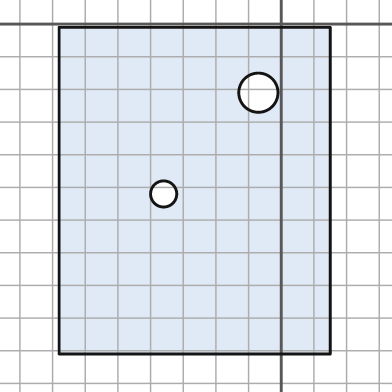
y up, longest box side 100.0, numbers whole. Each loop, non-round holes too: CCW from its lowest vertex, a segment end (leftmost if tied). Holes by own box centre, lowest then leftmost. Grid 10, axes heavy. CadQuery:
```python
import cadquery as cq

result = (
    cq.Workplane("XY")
    .moveTo(-68.0, -101.0)
    .lineTo(15.0, -101.0)
    .lineTo(15.0, -1.0)
    .lineTo(-68.0, -1.0)
    .close()
    .moveTo(-36.0, -52.0)
    .circle(4.0)
    .moveTo(-7.0, -21.0)
    .circle(6.0)
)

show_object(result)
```